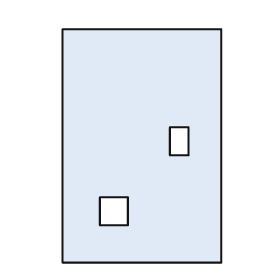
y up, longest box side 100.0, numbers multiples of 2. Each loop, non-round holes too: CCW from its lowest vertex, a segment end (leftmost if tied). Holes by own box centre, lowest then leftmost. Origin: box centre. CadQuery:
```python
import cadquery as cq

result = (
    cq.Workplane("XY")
    .moveTo(-34.0, -50.0)
    .lineTo(34.0, -50.0)
    .lineTo(34.0, 50.0)
    .lineTo(-34.0, 50.0)
    .close()
    .moveTo(-18.0, -34.0)
    .lineTo(-6.0, -34.0)
    .lineTo(-6.0, -22.0)
    .lineTo(-18.0, -22.0)
    .close()
    .moveTo(12.0, -4.0)
    .lineTo(20.0, -4.0)
    .lineTo(20.0, 8.0)
    .lineTo(12.0, 8.0)
    .close()
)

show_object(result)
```